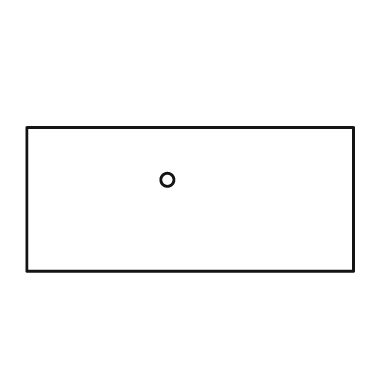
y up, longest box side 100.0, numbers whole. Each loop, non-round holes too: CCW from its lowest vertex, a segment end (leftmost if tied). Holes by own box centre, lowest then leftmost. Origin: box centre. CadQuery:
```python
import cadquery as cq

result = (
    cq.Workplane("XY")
    .moveTo(-50.0, -22.0)
    .lineTo(50.0, -22.0)
    .lineTo(50.0, 22.0)
    .lineTo(-50.0, 22.0)
    .close()
    .moveTo(-7.0, 6.0)
    .circle(2.0)
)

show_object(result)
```